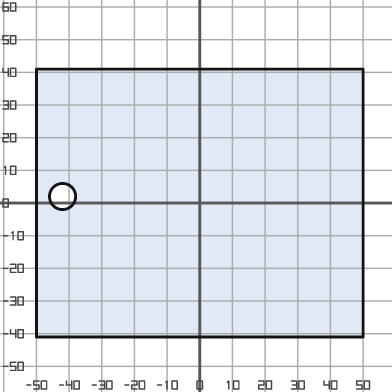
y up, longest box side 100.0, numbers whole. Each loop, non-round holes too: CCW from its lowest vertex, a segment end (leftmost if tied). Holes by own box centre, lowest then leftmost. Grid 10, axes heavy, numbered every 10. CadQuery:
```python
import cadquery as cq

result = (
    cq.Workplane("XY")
    .moveTo(-50.0, -41.0)
    .lineTo(50.0, -41.0)
    .lineTo(50.0, 41.0)
    .lineTo(-50.0, 41.0)
    .close()
    .moveTo(-42.0, 2.0)
    .circle(4.0)
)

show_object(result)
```